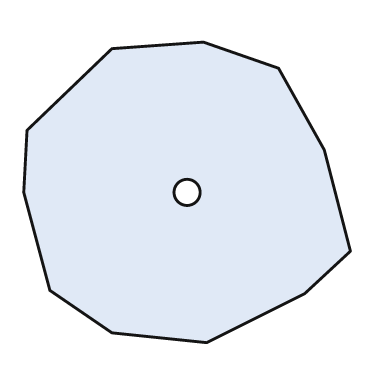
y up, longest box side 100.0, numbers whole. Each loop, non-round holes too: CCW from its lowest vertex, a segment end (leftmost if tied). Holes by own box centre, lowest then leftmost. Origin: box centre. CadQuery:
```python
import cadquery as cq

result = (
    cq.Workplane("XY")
    .moveTo(6.0, -46.0)
    .lineTo(36.0, -31.0)
    .lineTo(50.0, -18.0)
    .lineTo(42.0, 13.0)
    .lineTo(28.0, 38.0)
    .lineTo(5.0, 46.0)
    .lineTo(-23.0, 44.0)
    .lineTo(-49.0, 19.0)
    .lineTo(-50.0, 0.0)
    .lineTo(-42.0, -30.0)
    .lineTo(-23.0, -43.0)
    .close()
    .moveTo(0.0, 0.0)
    .circle(4.0)
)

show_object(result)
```